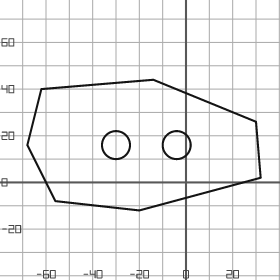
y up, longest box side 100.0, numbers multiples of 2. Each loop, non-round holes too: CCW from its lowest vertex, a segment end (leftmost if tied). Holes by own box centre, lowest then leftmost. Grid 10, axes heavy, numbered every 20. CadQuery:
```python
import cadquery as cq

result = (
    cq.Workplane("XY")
    .moveTo(-20.0, -12.0)
    .lineTo(32.0, 2.0)
    .lineTo(30.0, 26.0)
    .lineTo(-14.0, 44.0)
    .lineTo(-62.0, 40.0)
    .lineTo(-68.0, 16.0)
    .lineTo(-56.0, -8.0)
    .close()
    .moveTo(-30.0, 16.0)
    .circle(6.0)
    .moveTo(-4.0, 16.0)
    .circle(6.0)
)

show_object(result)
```